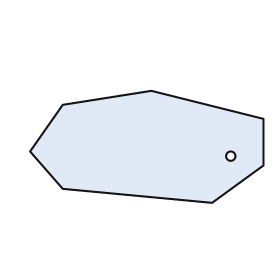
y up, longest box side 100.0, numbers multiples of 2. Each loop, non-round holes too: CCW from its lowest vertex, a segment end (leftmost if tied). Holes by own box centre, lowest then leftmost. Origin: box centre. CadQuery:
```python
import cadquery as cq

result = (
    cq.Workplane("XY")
    .moveTo(28.0, -24.0)
    .lineTo(50.0, -8.0)
    .lineTo(50.0, 12.0)
    .lineTo(2.0, 24.0)
    .lineTo(-36.0, 18.0)
    .lineTo(-50.0, -2.0)
    .lineTo(-36.0, -18.0)
    .close()
    .moveTo(36.0, -4.0)
    .circle(2.0)
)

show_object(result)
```